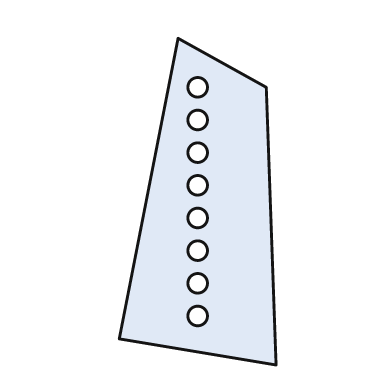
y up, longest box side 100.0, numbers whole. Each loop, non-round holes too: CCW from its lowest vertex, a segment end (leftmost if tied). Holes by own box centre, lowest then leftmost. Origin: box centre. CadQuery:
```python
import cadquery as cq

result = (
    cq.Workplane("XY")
    .moveTo(24.0, -50.0)
    .lineTo(21.0, 35.0)
    .lineTo(-6.0, 50.0)
    .lineTo(-24.0, -42.0)
    .close()
    .moveTo(0.0, -35.0)
    .circle(3.0)
    .moveTo(0.0, -25.0)
    .circle(3.0)
    .moveTo(0.0, -15.0)
    .circle(3.0)
    .moveTo(0.0, -5.0)
    .circle(3.0)
    .moveTo(0.0, 5.0)
    .circle(3.0)
    .moveTo(0.0, 15.0)
    .circle(3.0)
    .moveTo(0.0, 25.0)
    .circle(3.0)
    .moveTo(0.0, 35.0)
    .circle(3.0)
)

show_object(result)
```